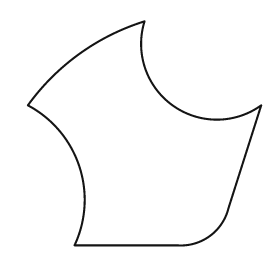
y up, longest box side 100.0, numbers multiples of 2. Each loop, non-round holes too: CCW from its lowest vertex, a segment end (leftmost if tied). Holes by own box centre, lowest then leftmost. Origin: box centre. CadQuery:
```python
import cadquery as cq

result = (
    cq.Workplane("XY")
    .moveTo(-30.0, -48.0)
    .lineTo(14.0, -48.0)
    .threePointArc((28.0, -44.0), (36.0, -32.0))
    .lineTo(50.0, 12.0)
    .threePointArc((12.0, 12.0), (0.0, 48.0))
    .threePointArc((-28.0, 34.0), (-50.0, 12.0))
    .threePointArc((-28.0, -14.0), (-30.0, -48.0))
    .close()
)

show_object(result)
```